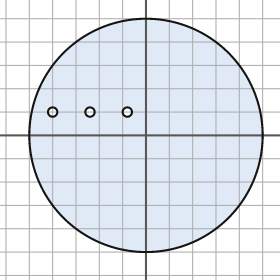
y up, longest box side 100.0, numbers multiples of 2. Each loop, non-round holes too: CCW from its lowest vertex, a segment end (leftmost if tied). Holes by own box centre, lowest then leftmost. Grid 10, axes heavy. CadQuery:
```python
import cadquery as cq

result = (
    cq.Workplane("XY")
    .moveTo(0.0, 0.0)
    .circle(50.0)
    .moveTo(-40.0, 10.0)
    .circle(2.0)
    .moveTo(-24.0, 10.0)
    .circle(2.0)
    .moveTo(-8.0, 10.0)
    .circle(2.0)
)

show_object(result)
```